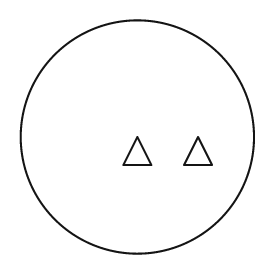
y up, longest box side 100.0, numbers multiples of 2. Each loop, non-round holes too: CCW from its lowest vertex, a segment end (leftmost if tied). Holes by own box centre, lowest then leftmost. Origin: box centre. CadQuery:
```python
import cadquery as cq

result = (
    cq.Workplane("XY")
    .moveTo(0.0, 0.0)
    .circle(50.0)
    .moveTo(-6.0, -12.0)
    .lineTo(6.0, -12.0)
    .lineTo(0.0, 0.0)
    .close()
    .moveTo(20.0, -12.0)
    .lineTo(32.0, -12.0)
    .lineTo(26.0, 0.0)
    .close()
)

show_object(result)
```